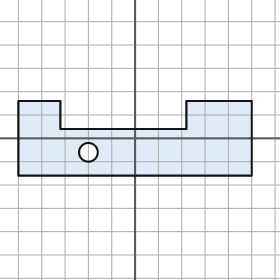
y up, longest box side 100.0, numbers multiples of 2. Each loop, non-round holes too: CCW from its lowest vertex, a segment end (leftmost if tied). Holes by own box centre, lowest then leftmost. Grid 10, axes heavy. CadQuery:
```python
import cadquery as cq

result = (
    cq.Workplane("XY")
    .moveTo(-50.0, -16.0)
    .lineTo(50.0, -16.0)
    .lineTo(50.0, 16.0)
    .lineTo(22.0, 16.0)
    .lineTo(22.0, 4.0)
    .lineTo(-32.0, 4.0)
    .lineTo(-32.0, 16.0)
    .lineTo(-50.0, 16.0)
    .close()
    .moveTo(-20.0, -6.0)
    .circle(4.0)
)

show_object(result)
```